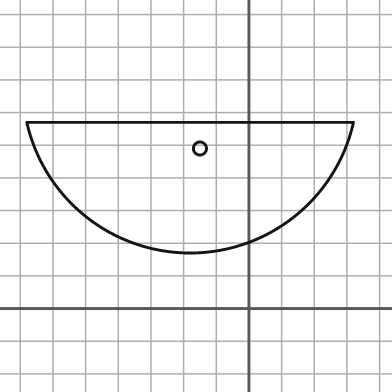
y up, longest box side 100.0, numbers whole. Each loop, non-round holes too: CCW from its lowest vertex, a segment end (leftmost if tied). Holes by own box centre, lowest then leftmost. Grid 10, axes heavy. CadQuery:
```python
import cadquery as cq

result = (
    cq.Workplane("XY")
    .moveTo(-68.0, 57.0)
    .threePointArc((-18.0, 17.0), (32.0, 57.0))
    .close()
    .moveTo(-15.0, 49.0)
    .circle(2.0)
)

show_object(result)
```